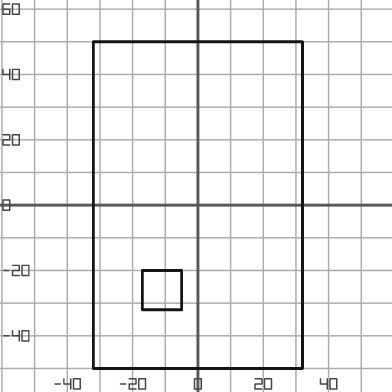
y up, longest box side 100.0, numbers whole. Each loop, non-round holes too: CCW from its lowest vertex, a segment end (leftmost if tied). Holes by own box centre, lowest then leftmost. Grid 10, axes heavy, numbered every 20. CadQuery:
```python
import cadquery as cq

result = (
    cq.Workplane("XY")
    .moveTo(-32.0, -50.0)
    .lineTo(32.0, -50.0)
    .lineTo(32.0, 50.0)
    .lineTo(-32.0, 50.0)
    .close()
    .moveTo(-17.0, -32.0)
    .lineTo(-5.0, -32.0)
    .lineTo(-5.0, -20.0)
    .lineTo(-17.0, -20.0)
    .close()
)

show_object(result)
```